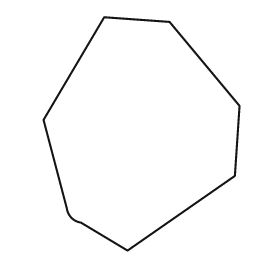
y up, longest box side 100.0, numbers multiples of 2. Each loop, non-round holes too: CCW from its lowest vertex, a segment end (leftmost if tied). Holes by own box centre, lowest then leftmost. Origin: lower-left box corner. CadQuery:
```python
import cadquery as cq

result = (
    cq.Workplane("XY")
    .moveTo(36.0, 0.0)
    .lineTo(82.0, 32.0)
    .lineTo(84.0, 62.0)
    .lineTo(54.0, 98.0)
    .lineTo(26.0, 100.0)
    .lineTo(0.0, 56.0)
    .lineTo(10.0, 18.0)
    .threePointArc((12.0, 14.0), (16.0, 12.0))
    .close()
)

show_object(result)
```